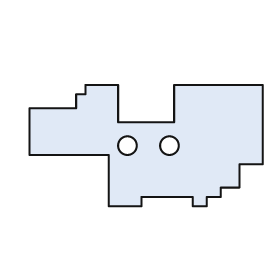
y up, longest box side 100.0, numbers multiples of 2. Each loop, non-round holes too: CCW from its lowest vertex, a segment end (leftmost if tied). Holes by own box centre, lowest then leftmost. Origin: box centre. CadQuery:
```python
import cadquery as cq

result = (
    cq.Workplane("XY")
    .moveTo(-16.0, -26.0)
    .lineTo(-2.0, -26.0)
    .lineTo(-2.0, -22.0)
    .lineTo(20.0, -22.0)
    .lineTo(20.0, -26.0)
    .lineTo(26.0, -26.0)
    .lineTo(26.0, -22.0)
    .lineTo(32.0, -22.0)
    .lineTo(32.0, -18.0)
    .lineTo(40.0, -18.0)
    .lineTo(40.0, -8.0)
    .lineTo(50.0, -8.0)
    .lineTo(50.0, 26.0)
    .lineTo(12.0, 26.0)
    .lineTo(12.0, 10.0)
    .lineTo(-12.0, 10.0)
    .lineTo(-12.0, 26.0)
    .lineTo(-26.0, 26.0)
    .lineTo(-26.0, 22.0)
    .lineTo(-30.0, 22.0)
    .lineTo(-30.0, 16.0)
    .lineTo(-50.0, 16.0)
    .lineTo(-50.0, -4.0)
    .lineTo(-16.0, -4.0)
    .close()
    .moveTo(-8.0, 0.0)
    .circle(4.0)
    .moveTo(10.0, 0.0)
    .circle(4.0)
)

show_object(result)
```